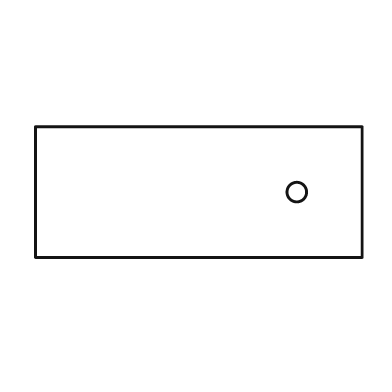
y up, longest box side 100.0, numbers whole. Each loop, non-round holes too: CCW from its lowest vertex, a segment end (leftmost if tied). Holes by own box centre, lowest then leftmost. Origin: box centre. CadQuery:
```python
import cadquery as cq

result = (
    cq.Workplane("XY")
    .moveTo(-50.0, -20.0)
    .lineTo(50.0, -20.0)
    .lineTo(50.0, 20.0)
    .lineTo(-50.0, 20.0)
    .close()
    .moveTo(30.0, 0.0)
    .circle(3.0)
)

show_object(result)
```